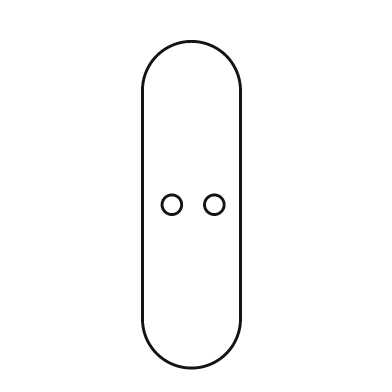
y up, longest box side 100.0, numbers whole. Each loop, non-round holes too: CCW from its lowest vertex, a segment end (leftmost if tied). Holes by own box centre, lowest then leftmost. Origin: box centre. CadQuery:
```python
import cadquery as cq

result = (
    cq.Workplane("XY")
    .moveTo(-15.0, -35.0)
    .threePointArc((0.0, -50.0), (15.0, -35.0))
    .lineTo(15.0, 35.0)
    .threePointArc((0.0, 50.0), (-15.0, 35.0))
    .close()
    .moveTo(-6.0, 0.0)
    .circle(3.0)
    .moveTo(7.0, 0.0)
    .circle(3.0)
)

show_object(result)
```